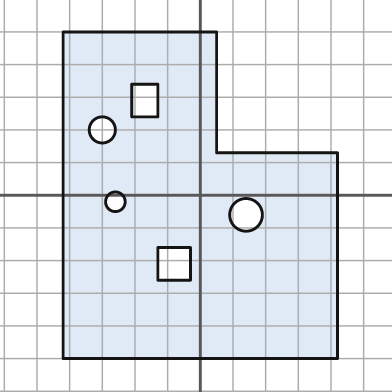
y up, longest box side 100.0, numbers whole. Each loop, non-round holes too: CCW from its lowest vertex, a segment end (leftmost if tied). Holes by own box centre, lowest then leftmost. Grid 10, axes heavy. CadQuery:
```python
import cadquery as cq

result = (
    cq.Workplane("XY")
    .moveTo(-42.0, -50.0)
    .lineTo(42.0, -50.0)
    .lineTo(42.0, 13.0)
    .lineTo(5.0, 13.0)
    .lineTo(5.0, 50.0)
    .lineTo(-42.0, 50.0)
    .close()
    .moveTo(-13.0, -26.0)
    .lineTo(-3.0, -26.0)
    .lineTo(-3.0, -16.0)
    .lineTo(-13.0, -16.0)
    .close()
    .moveTo(14.0, -6.0)
    .circle(5.0)
    .moveTo(-26.0, -2.0)
    .circle(3.0)
    .moveTo(-30.0, 20.0)
    .circle(4.0)
    .moveTo(-21.0, 24.0)
    .lineTo(-13.0, 24.0)
    .lineTo(-13.0, 34.0)
    .lineTo(-21.0, 34.0)
    .close()
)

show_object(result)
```